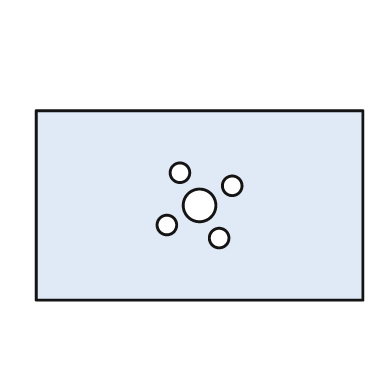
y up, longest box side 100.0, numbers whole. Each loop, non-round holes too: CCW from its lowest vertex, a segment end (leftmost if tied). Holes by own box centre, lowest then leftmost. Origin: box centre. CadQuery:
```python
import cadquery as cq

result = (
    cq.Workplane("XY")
    .moveTo(-50.0, -29.0)
    .lineTo(50.0, -29.0)
    .lineTo(50.0, 29.0)
    .lineTo(-50.0, 29.0)
    .close()
    .moveTo(6.0, -10.0)
    .circle(3.0)
    .moveTo(-10.0, -6.0)
    .circle(3.0)
    .moveTo(0.0, 0.0)
    .circle(5.0)
    .moveTo(10.0, 6.0)
    .circle(3.0)
    .moveTo(-6.0, 10.0)
    .circle(3.0)
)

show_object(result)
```